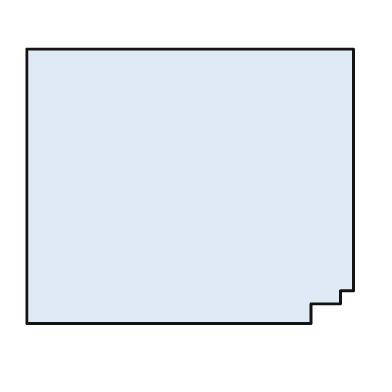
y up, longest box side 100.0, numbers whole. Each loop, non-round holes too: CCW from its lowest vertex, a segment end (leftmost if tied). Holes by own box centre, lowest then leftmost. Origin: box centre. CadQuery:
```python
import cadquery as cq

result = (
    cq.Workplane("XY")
    .moveTo(-50.0, -42.0)
    .lineTo(37.0, -42.0)
    .lineTo(37.0, -36.0)
    .lineTo(46.0, -36.0)
    .lineTo(46.0, -32.0)
    .lineTo(50.0, -32.0)
    .lineTo(50.0, 42.0)
    .lineTo(-50.0, 42.0)
    .close()
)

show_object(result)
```